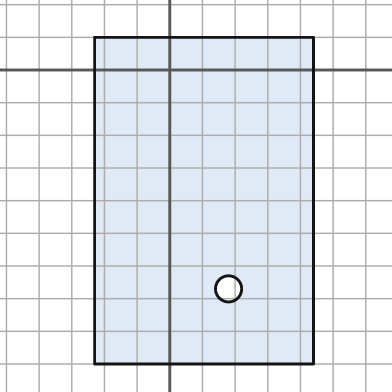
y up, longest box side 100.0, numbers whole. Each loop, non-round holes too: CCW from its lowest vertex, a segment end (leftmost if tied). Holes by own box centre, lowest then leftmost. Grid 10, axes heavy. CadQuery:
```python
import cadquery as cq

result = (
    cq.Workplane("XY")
    .moveTo(-23.0, -90.0)
    .lineTo(44.0, -90.0)
    .lineTo(44.0, 10.0)
    .lineTo(-23.0, 10.0)
    .close()
    .moveTo(18.0, -67.0)
    .circle(4.0)
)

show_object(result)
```